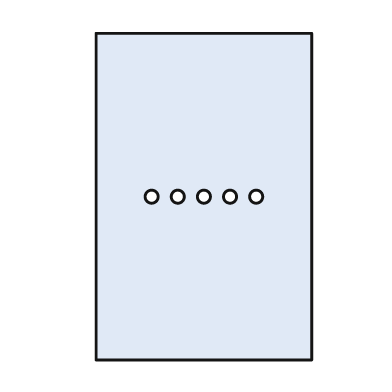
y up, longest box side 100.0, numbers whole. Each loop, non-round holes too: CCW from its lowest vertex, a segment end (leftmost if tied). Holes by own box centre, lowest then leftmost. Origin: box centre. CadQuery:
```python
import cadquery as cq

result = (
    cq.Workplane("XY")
    .moveTo(-33.0, -50.0)
    .lineTo(33.0, -50.0)
    .lineTo(33.0, 50.0)
    .lineTo(-33.0, 50.0)
    .close()
    .moveTo(-16.0, 0.0)
    .circle(2.0)
    .moveTo(-8.0, 0.0)
    .circle(2.0)
    .moveTo(0.0, 0.0)
    .circle(2.0)
    .moveTo(8.0, 0.0)
    .circle(2.0)
    .moveTo(16.0, 0.0)
    .circle(2.0)
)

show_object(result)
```